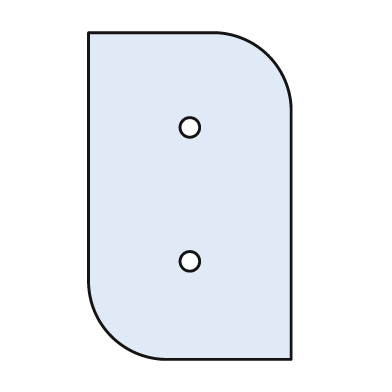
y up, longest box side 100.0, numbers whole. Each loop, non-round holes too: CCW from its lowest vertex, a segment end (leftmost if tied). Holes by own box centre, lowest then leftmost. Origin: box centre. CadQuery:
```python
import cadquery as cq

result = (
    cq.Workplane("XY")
    .moveTo(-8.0, -50.0)
    .lineTo(31.0, -50.0)
    .lineTo(31.0, 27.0)
    .threePointArc((24.0, 43.0), (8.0, 50.0))
    .lineTo(-31.0, 50.0)
    .lineTo(-31.0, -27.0)
    .threePointArc((-24.0, -43.0), (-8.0, -50.0))
    .close()
    .moveTo(0.0, -20.0)
    .circle(3.0)
    .moveTo(0.0, 21.0)
    .circle(3.0)
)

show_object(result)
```